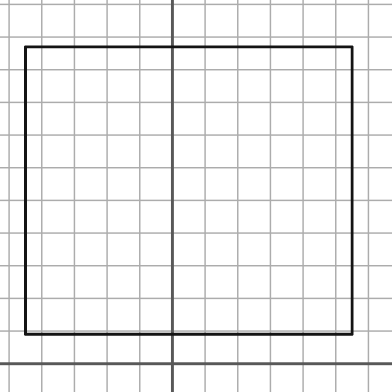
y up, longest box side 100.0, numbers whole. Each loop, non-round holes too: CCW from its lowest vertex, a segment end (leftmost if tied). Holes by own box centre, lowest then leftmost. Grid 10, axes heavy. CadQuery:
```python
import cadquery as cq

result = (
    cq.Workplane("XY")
    .moveTo(-45.0, 9.0)
    .lineTo(55.0, 9.0)
    .lineTo(55.0, 97.0)
    .lineTo(-45.0, 97.0)
    .close()
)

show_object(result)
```